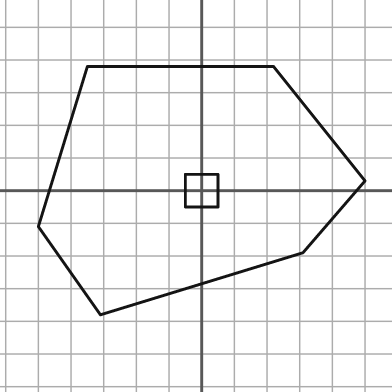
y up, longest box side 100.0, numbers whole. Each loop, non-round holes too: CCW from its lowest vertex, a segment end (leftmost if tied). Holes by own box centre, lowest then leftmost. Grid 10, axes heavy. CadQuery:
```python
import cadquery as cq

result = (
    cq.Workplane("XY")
    .moveTo(-31.0, -38.0)
    .lineTo(31.0, -19.0)
    .lineTo(50.0, 3.0)
    .lineTo(22.0, 38.0)
    .lineTo(-35.0, 38.0)
    .lineTo(-50.0, -11.0)
    .close()
    .moveTo(-5.0, -5.0)
    .lineTo(5.0, -5.0)
    .lineTo(5.0, 5.0)
    .lineTo(-5.0, 5.0)
    .close()
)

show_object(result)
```